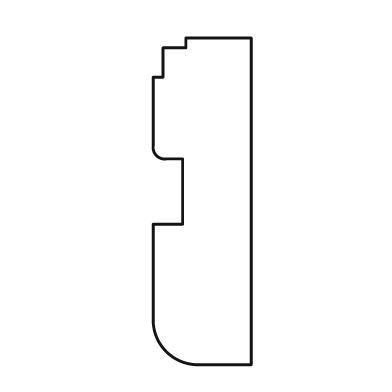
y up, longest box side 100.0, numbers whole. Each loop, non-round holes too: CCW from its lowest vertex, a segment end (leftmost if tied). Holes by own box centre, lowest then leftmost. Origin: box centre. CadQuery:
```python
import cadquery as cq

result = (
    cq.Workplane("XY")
    .moveTo(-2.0, -50.0)
    .lineTo(15.0, -50.0)
    .lineTo(15.0, 50.0)
    .lineTo(-5.0, 50.0)
    .lineTo(-5.0, 47.0)
    .lineTo(-12.0, 47.0)
    .lineTo(-12.0, 38.0)
    .lineTo(-15.0, 38.0)
    .lineTo(-15.0, 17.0)
    .threePointArc((-14.0, 14.0), (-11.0, 13.0))
    .lineTo(-6.0, 13.0)
    .lineTo(-6.0, -7.0)
    .lineTo(-15.0, -7.0)
    .lineTo(-15.0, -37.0)
    .threePointArc((-11.0, -46.0), (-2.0, -50.0))
    .close()
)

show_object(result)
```